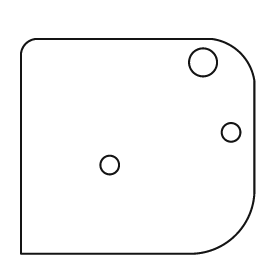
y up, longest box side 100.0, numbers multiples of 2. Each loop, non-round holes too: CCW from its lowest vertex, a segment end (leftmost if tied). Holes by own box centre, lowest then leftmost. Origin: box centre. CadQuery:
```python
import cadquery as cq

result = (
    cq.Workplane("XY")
    .moveTo(-50.0, -46.0)
    .lineTo(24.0, -46.0)
    .threePointArc((42.0, -38.0), (50.0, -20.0))
    .lineTo(50.0, 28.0)
    .threePointArc((44.0, 40.0), (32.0, 46.0))
    .lineTo(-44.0, 46.0)
    .threePointArc((-48.0, 44.0), (-50.0, 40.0))
    .close()
    .moveTo(-12.0, -8.0)
    .circle(4.0)
    .moveTo(40.0, 6.0)
    .circle(4.0)
    .moveTo(28.0, 36.0)
    .circle(6.0)
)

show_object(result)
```